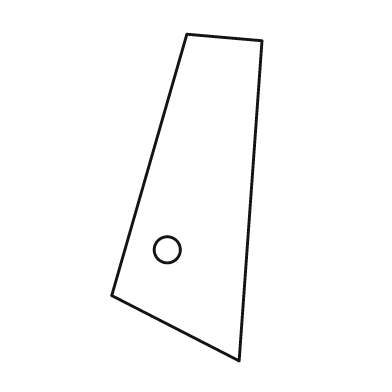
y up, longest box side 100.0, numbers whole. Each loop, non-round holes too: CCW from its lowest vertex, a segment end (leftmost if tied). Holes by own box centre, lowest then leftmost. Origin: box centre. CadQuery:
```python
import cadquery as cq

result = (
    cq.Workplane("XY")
    .moveTo(16.0, -50.0)
    .lineTo(23.0, 48.0)
    .lineTo(0.0, 50.0)
    .lineTo(-23.0, -30.0)
    .close()
    .moveTo(-6.0, -16.0)
    .circle(4.0)
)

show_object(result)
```